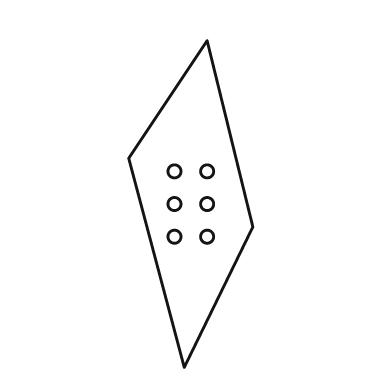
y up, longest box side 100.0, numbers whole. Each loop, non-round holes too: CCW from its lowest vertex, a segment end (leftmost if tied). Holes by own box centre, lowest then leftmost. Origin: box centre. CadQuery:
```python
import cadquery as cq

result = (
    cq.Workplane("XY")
    .moveTo(-2.0, -50.0)
    .lineTo(19.0, -7.0)
    .lineTo(5.0, 50.0)
    .lineTo(-19.0, 14.0)
    .close()
    .moveTo(-5.0, -10.0)
    .circle(2.0)
    .moveTo(5.0, -10.0)
    .circle(2.0)
    .moveTo(-5.0, 0.0)
    .circle(2.0)
    .moveTo(5.0, 0.0)
    .circle(2.0)
    .moveTo(-5.0, 10.0)
    .circle(2.0)
    .moveTo(5.0, 10.0)
    .circle(2.0)
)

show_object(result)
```